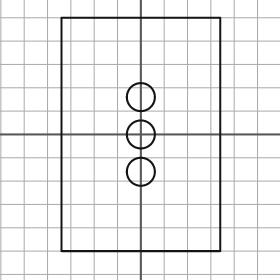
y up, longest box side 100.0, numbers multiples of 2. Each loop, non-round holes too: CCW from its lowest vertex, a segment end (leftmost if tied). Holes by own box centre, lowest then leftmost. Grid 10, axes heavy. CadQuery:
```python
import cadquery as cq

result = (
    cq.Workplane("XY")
    .moveTo(-34.0, -50.0)
    .lineTo(34.0, -50.0)
    .lineTo(34.0, 50.0)
    .lineTo(-34.0, 50.0)
    .close()
    .moveTo(0.0, -16.0)
    .circle(6.0)
    .moveTo(0.0, 0.0)
    .circle(6.0)
    .moveTo(0.0, 16.0)
    .circle(6.0)
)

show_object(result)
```